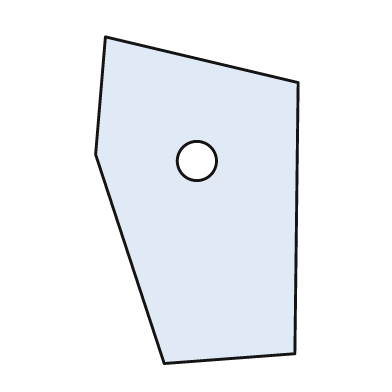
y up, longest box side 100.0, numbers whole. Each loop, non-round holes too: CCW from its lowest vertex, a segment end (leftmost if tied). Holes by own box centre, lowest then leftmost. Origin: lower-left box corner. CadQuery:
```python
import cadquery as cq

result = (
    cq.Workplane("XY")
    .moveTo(21.0, 0.0)
    .lineTo(61.0, 3.0)
    .lineTo(62.0, 86.0)
    .lineTo(3.0, 100.0)
    .lineTo(0.0, 64.0)
    .close()
    .moveTo(31.0, 62.0)
    .circle(6.0)
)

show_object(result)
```